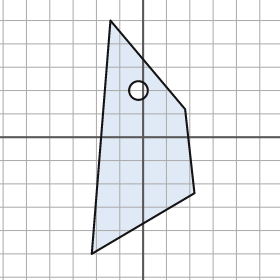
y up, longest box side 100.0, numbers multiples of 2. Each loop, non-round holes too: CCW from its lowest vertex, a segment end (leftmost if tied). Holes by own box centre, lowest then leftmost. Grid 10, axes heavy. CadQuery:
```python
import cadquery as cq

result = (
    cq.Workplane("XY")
    .moveTo(-22.0, -50.0)
    .lineTo(22.0, -24.0)
    .lineTo(18.0, 12.0)
    .lineTo(-14.0, 50.0)
    .close()
    .moveTo(-2.0, 20.0)
    .circle(4.0)
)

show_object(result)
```